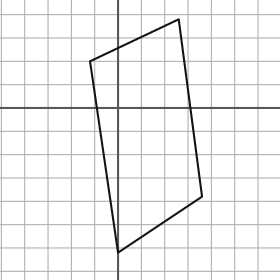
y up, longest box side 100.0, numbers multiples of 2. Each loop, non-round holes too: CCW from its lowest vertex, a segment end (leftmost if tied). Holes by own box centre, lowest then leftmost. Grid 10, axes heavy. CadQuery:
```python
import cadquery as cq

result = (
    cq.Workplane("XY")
    .moveTo(0.0, -62.0)
    .lineTo(36.0, -38.0)
    .lineTo(26.0, 38.0)
    .lineTo(-12.0, 20.0)
    .close()
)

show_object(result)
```